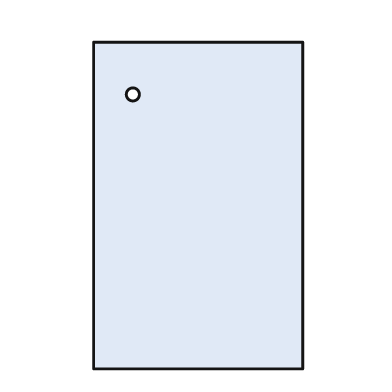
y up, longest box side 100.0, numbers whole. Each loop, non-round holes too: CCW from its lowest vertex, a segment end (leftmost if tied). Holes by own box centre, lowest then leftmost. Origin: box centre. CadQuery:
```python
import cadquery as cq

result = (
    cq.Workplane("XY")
    .moveTo(-32.0, -50.0)
    .lineTo(32.0, -50.0)
    .lineTo(32.0, 50.0)
    .lineTo(-32.0, 50.0)
    .close()
    .moveTo(-20.0, 34.0)
    .circle(2.0)
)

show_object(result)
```